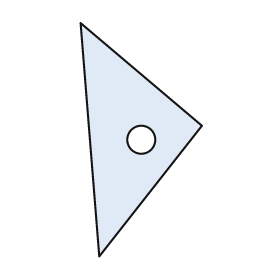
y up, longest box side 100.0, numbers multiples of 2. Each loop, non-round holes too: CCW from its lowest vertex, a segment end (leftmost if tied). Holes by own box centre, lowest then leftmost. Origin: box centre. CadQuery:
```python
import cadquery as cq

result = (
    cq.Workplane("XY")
    .moveTo(-18.0, -50.0)
    .lineTo(26.0, 6.0)
    .lineTo(-26.0, 50.0)
    .close()
    .moveTo(0.0, 0.0)
    .circle(6.0)
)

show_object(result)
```